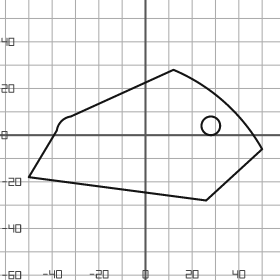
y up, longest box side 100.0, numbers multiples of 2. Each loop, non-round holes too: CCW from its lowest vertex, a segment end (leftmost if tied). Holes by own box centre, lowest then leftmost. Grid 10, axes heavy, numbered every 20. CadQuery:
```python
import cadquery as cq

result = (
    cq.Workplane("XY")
    .moveTo(26.0, -28.0)
    .lineTo(50.0, -6.0)
    .threePointArc((34.0, 14.0), (12.0, 28.0))
    .lineTo(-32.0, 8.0)
    .threePointArc((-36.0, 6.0), (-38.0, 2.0))
    .lineTo(-50.0, -18.0)
    .close()
    .moveTo(28.0, 4.0)
    .circle(4.0)
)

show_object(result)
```